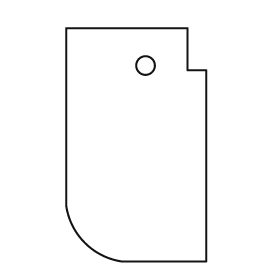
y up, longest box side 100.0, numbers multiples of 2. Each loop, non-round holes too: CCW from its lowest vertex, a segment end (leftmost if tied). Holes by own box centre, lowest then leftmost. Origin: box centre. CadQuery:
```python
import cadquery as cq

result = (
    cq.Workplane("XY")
    .moveTo(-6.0, -50.0)
    .lineTo(30.0, -50.0)
    .lineTo(30.0, 32.0)
    .lineTo(22.0, 32.0)
    .lineTo(22.0, 50.0)
    .lineTo(-30.0, 50.0)
    .lineTo(-30.0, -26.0)
    .threePointArc((-22.0, -42.0), (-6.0, -50.0))
    .close()
    .moveTo(4.0, 34.0)
    .circle(4.0)
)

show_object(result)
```